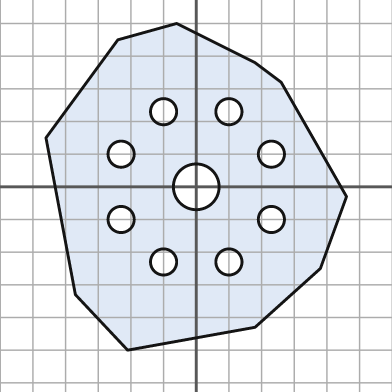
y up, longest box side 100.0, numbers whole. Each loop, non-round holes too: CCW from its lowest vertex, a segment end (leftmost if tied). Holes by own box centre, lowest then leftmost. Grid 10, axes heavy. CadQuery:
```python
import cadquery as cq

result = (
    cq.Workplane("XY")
    .moveTo(-21.0, -50.0)
    .lineTo(18.0, -43.0)
    .lineTo(38.0, -25.0)
    .lineTo(46.0, -3.0)
    .lineTo(26.0, 32.0)
    .lineTo(18.0, 38.0)
    .lineTo(-6.0, 50.0)
    .lineTo(-24.0, 45.0)
    .lineTo(-46.0, 15.0)
    .lineTo(-37.0, -33.0)
    .close()
    .moveTo(-10.0, -23.0)
    .circle(4.0)
    .moveTo(10.0, -23.0)
    .circle(4.0)
    .moveTo(-23.0, -10.0)
    .circle(4.0)
    .moveTo(23.0, -10.0)
    .circle(4.0)
    .moveTo(0.0, 0.0)
    .circle(7.0)
    .moveTo(-23.0, 10.0)
    .circle(4.0)
    .moveTo(23.0, 10.0)
    .circle(4.0)
    .moveTo(-10.0, 23.0)
    .circle(4.0)
    .moveTo(10.0, 23.0)
    .circle(4.0)
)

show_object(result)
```